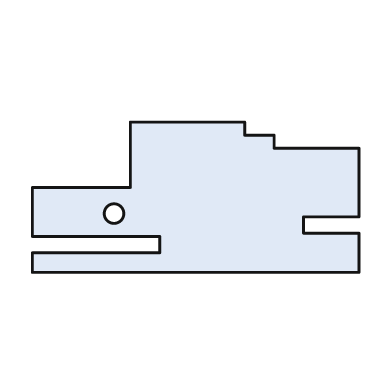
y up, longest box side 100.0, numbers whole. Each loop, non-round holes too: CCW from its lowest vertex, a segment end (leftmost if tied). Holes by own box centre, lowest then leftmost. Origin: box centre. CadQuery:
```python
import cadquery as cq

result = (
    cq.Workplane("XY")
    .moveTo(-50.0, -23.0)
    .lineTo(50.0, -23.0)
    .lineTo(50.0, -11.0)
    .lineTo(33.0, -11.0)
    .lineTo(33.0, -6.0)
    .lineTo(50.0, -6.0)
    .lineTo(50.0, 15.0)
    .lineTo(24.0, 15.0)
    .lineTo(24.0, 19.0)
    .lineTo(15.0, 19.0)
    .lineTo(15.0, 23.0)
    .lineTo(-20.0, 23.0)
    .lineTo(-20.0, 3.0)
    .lineTo(-50.0, 3.0)
    .lineTo(-50.0, -12.0)
    .lineTo(-11.0, -12.0)
    .lineTo(-11.0, -17.0)
    .lineTo(-50.0, -17.0)
    .close()
    .moveTo(-25.0, -5.0)
    .circle(3.0)
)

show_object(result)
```